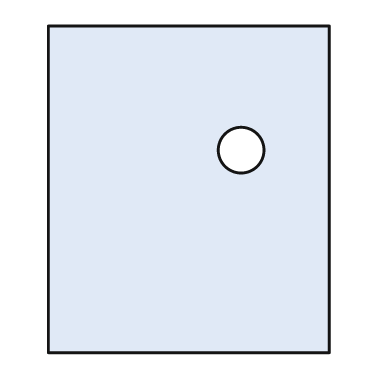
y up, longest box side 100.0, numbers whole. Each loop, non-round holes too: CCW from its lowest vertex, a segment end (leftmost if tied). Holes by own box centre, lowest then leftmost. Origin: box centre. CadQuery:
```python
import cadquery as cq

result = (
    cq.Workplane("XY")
    .moveTo(-43.0, -50.0)
    .lineTo(43.0, -50.0)
    .lineTo(43.0, 50.0)
    .lineTo(-43.0, 50.0)
    .close()
    .moveTo(16.0, 12.0)
    .circle(7.0)
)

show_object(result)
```